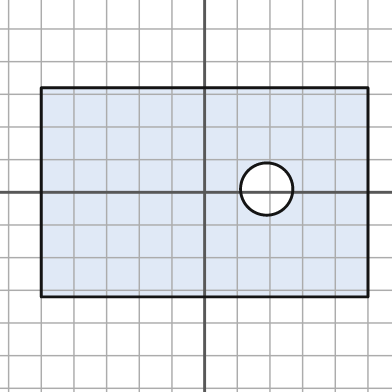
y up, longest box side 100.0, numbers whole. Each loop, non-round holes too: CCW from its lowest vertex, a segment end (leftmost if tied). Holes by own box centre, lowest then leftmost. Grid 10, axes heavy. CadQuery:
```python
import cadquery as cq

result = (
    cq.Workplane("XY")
    .moveTo(-50.0, -32.0)
    .lineTo(50.0, -32.0)
    .lineTo(50.0, 32.0)
    .lineTo(-50.0, 32.0)
    .close()
    .moveTo(19.0, 1.0)
    .circle(8.0)
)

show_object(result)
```